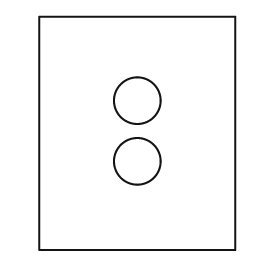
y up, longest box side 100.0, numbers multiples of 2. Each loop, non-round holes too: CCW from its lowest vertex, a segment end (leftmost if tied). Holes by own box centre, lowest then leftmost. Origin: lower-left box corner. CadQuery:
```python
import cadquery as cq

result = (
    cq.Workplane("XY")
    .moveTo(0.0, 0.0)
    .lineTo(84.0, 0.0)
    .lineTo(84.0, 100.0)
    .lineTo(0.0, 100.0)
    .close()
    .moveTo(42.0, 38.0)
    .circle(10.0)
    .moveTo(42.0, 64.0)
    .circle(10.0)
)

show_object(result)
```